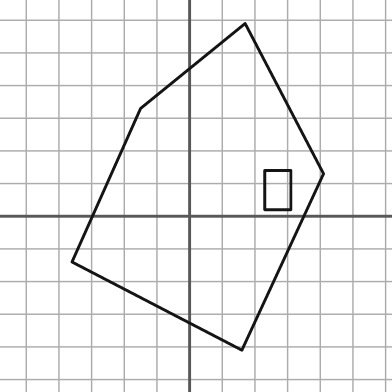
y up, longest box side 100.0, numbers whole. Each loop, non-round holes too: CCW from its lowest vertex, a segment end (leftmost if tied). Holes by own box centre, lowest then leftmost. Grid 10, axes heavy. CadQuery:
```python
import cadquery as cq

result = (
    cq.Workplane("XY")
    .moveTo(16.0, -41.0)
    .lineTo(41.0, 13.0)
    .lineTo(17.0, 59.0)
    .lineTo(-15.0, 33.0)
    .lineTo(-36.0, -14.0)
    .close()
    .moveTo(23.0, 2.0)
    .lineTo(31.0, 2.0)
    .lineTo(31.0, 14.0)
    .lineTo(23.0, 14.0)
    .close()
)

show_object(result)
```